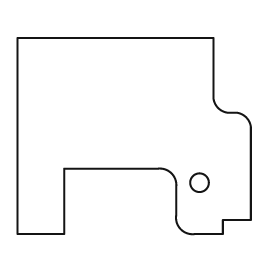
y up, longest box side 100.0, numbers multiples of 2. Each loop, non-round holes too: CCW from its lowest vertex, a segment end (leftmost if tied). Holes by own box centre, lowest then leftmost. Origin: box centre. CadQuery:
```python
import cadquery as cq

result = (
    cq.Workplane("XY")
    .moveTo(-50.0, -42.0)
    .lineTo(-30.0, -42.0)
    .lineTo(-30.0, -14.0)
    .lineTo(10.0, -14.0)
    .threePointArc((16.0, -16.0), (18.0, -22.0))
    .lineTo(18.0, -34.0)
    .threePointArc((20.0, -40.0), (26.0, -42.0))
    .lineTo(38.0, -42.0)
    .lineTo(38.0, -36.0)
    .lineTo(50.0, -36.0)
    .lineTo(50.0, 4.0)
    .threePointArc((48.0, 8.0), (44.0, 10.0))
    .lineTo(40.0, 10.0)
    .threePointArc((36.0, 12.0), (34.0, 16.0))
    .lineTo(34.0, 42.0)
    .lineTo(-50.0, 42.0)
    .close()
    .moveTo(28.0, -20.0)
    .circle(4.0)
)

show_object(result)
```